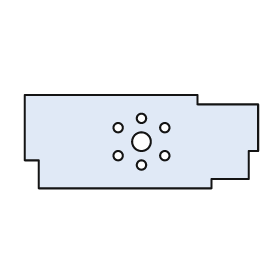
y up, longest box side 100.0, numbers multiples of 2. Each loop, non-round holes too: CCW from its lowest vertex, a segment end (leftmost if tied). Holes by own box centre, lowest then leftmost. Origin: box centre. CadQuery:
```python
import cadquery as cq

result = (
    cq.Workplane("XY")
    .moveTo(-44.0, -20.0)
    .lineTo(30.0, -20.0)
    .lineTo(30.0, -16.0)
    .lineTo(46.0, -16.0)
    .lineTo(46.0, -4.0)
    .lineTo(50.0, -4.0)
    .lineTo(50.0, 16.0)
    .lineTo(24.0, 16.0)
    .lineTo(24.0, 20.0)
    .lineTo(-50.0, 20.0)
    .lineTo(-50.0, -8.0)
    .lineTo(-44.0, -8.0)
    .close()
    .moveTo(0.0, -10.0)
    .circle(2.0)
    .moveTo(-10.0, -6.0)
    .circle(2.0)
    .moveTo(10.0, -6.0)
    .circle(2.0)
    .moveTo(0.0, 0.0)
    .circle(4.0)
    .moveTo(-10.0, 6.0)
    .circle(2.0)
    .moveTo(10.0, 6.0)
    .circle(2.0)
    .moveTo(0.0, 10.0)
    .circle(2.0)
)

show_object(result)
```